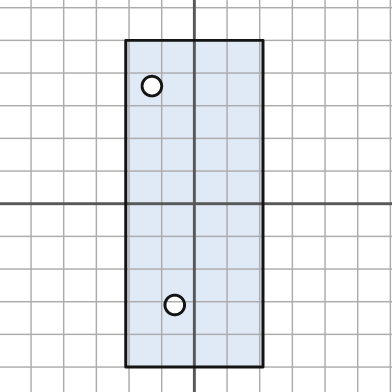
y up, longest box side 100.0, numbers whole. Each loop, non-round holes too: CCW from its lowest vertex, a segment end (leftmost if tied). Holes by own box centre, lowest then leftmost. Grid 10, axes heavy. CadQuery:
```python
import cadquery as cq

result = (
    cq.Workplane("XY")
    .moveTo(-21.0, -50.0)
    .lineTo(21.0, -50.0)
    .lineTo(21.0, 50.0)
    .lineTo(-21.0, 50.0)
    .close()
    .moveTo(-6.0, -31.0)
    .circle(3.0)
    .moveTo(-13.0, 36.0)
    .circle(3.0)
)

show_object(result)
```